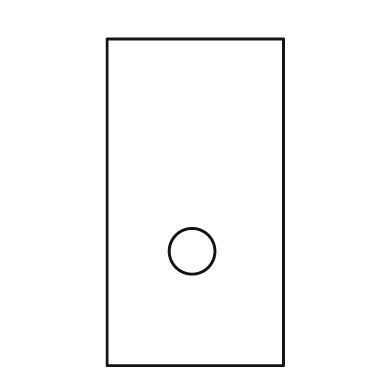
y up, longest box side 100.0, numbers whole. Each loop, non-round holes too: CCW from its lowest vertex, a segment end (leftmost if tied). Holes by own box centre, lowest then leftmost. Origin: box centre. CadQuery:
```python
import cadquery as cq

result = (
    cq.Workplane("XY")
    .moveTo(-27.0, -50.0)
    .lineTo(27.0, -50.0)
    .lineTo(27.0, 50.0)
    .lineTo(-27.0, 50.0)
    .close()
    .moveTo(-1.0, -15.0)
    .circle(7.0)
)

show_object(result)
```